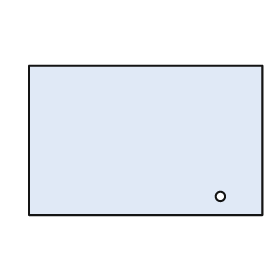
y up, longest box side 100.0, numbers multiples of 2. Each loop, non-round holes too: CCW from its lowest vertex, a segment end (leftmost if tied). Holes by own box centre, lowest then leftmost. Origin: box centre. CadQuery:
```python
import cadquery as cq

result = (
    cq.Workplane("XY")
    .moveTo(-50.0, -32.0)
    .lineTo(50.0, -32.0)
    .lineTo(50.0, 32.0)
    .lineTo(-50.0, 32.0)
    .close()
    .moveTo(32.0, -24.0)
    .circle(2.0)
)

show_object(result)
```